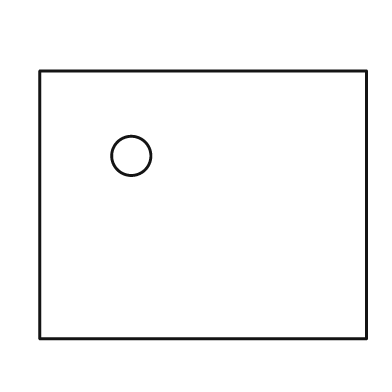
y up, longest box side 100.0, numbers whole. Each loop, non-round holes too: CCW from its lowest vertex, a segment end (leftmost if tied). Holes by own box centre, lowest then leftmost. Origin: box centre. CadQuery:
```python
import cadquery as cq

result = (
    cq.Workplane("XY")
    .moveTo(-50.0, -41.0)
    .lineTo(50.0, -41.0)
    .lineTo(50.0, 41.0)
    .lineTo(-50.0, 41.0)
    .close()
    .moveTo(-22.0, 15.0)
    .circle(6.0)
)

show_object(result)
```